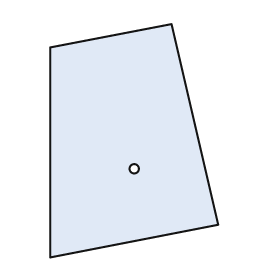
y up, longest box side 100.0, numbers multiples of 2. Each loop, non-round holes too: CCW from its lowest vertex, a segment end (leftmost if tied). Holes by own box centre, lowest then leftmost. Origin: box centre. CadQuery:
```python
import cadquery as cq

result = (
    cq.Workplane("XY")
    .moveTo(-36.0, -50.0)
    .lineTo(36.0, -36.0)
    .lineTo(16.0, 50.0)
    .lineTo(-36.0, 40.0)
    .close()
    .moveTo(0.0, -12.0)
    .circle(2.0)
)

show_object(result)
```